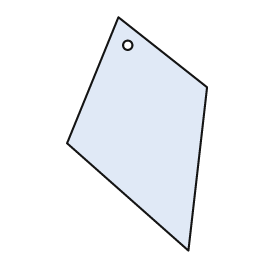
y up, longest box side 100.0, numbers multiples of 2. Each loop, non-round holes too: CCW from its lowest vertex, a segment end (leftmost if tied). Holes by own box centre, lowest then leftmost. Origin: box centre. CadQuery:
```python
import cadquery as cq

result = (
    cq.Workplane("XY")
    .moveTo(22.0, -50.0)
    .lineTo(30.0, 20.0)
    .lineTo(-8.0, 50.0)
    .lineTo(-30.0, -4.0)
    .close()
    .moveTo(-4.0, 38.0)
    .circle(2.0)
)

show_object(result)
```